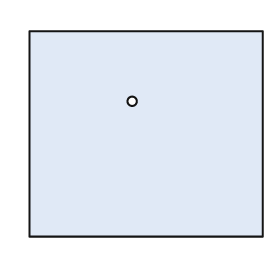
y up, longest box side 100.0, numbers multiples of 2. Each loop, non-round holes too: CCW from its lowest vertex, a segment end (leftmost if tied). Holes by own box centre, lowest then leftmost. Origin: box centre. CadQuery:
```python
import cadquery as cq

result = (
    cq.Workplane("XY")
    .moveTo(-50.0, -44.0)
    .lineTo(50.0, -44.0)
    .lineTo(50.0, 44.0)
    .lineTo(-50.0, 44.0)
    .close()
    .moveTo(-6.0, 14.0)
    .circle(2.0)
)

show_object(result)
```